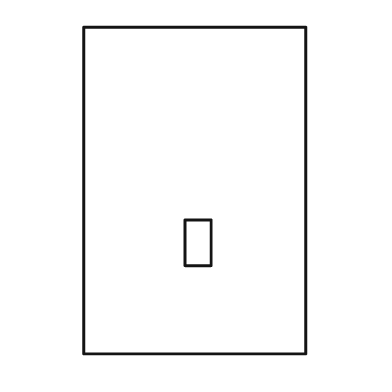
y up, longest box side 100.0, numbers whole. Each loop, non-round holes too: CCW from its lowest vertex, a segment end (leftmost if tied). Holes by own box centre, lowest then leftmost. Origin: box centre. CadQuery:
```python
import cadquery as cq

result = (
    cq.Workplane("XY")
    .moveTo(-34.0, -50.0)
    .lineTo(34.0, -50.0)
    .lineTo(34.0, 50.0)
    .lineTo(-34.0, 50.0)
    .close()
    .moveTo(-3.0, -23.0)
    .lineTo(5.0, -23.0)
    .lineTo(5.0, -9.0)
    .lineTo(-3.0, -9.0)
    .close()
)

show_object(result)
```